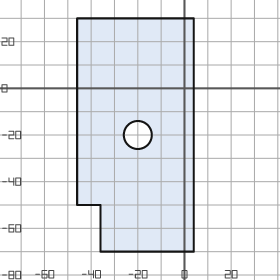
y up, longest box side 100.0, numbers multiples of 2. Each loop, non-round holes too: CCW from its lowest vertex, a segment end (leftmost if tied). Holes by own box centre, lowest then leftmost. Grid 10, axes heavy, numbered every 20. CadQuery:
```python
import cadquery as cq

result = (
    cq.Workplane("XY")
    .moveTo(-36.0, -70.0)
    .lineTo(4.0, -70.0)
    .lineTo(4.0, 30.0)
    .lineTo(-46.0, 30.0)
    .lineTo(-46.0, -50.0)
    .lineTo(-36.0, -50.0)
    .close()
    .moveTo(-20.0, -20.0)
    .circle(6.0)
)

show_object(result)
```